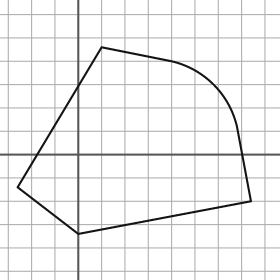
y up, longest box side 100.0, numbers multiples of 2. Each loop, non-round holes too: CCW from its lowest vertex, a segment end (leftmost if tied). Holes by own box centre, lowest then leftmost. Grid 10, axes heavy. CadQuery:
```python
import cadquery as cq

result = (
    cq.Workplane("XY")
    .moveTo(0.0, -34.0)
    .lineTo(74.0, -20.0)
    .lineTo(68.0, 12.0)
    .threePointArc((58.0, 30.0), (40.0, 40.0))
    .lineTo(10.0, 46.0)
    .lineTo(-26.0, -14.0)
    .close()
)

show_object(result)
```